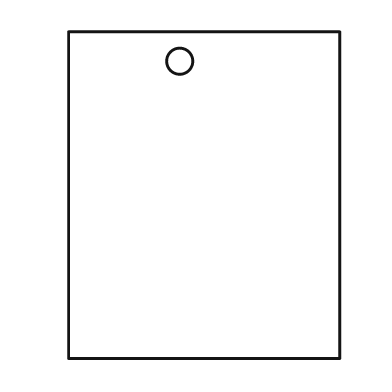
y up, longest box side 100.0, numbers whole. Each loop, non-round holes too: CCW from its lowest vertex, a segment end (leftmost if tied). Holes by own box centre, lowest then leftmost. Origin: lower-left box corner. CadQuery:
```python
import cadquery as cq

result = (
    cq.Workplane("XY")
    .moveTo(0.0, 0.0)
    .lineTo(83.0, 0.0)
    .lineTo(83.0, 100.0)
    .lineTo(0.0, 100.0)
    .close()
    .moveTo(34.0, 91.0)
    .circle(4.0)
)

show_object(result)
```